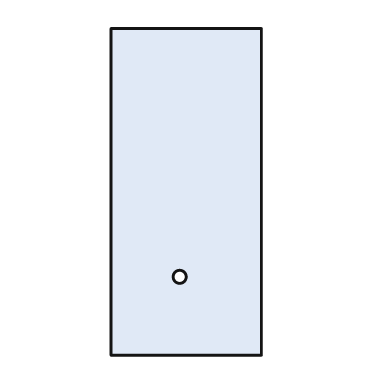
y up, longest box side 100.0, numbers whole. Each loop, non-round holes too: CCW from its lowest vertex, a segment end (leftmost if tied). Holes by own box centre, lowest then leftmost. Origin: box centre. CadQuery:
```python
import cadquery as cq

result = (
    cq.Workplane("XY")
    .moveTo(-23.0, -50.0)
    .lineTo(23.0, -50.0)
    .lineTo(23.0, 50.0)
    .lineTo(-23.0, 50.0)
    .close()
    .moveTo(-2.0, -26.0)
    .circle(2.0)
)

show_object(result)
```